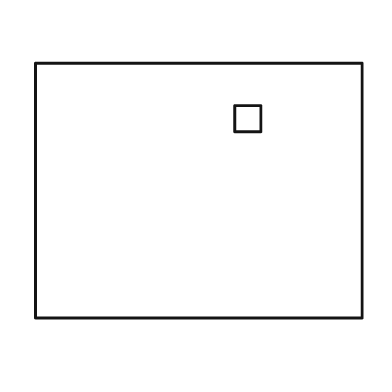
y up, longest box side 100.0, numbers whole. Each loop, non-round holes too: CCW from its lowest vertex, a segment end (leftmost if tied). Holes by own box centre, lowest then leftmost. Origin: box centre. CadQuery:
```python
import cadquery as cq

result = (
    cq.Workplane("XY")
    .moveTo(-50.0, -39.0)
    .lineTo(50.0, -39.0)
    .lineTo(50.0, 39.0)
    .lineTo(-50.0, 39.0)
    .close()
    .moveTo(11.0, 18.0)
    .lineTo(19.0, 18.0)
    .lineTo(19.0, 26.0)
    .lineTo(11.0, 26.0)
    .close()
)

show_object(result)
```